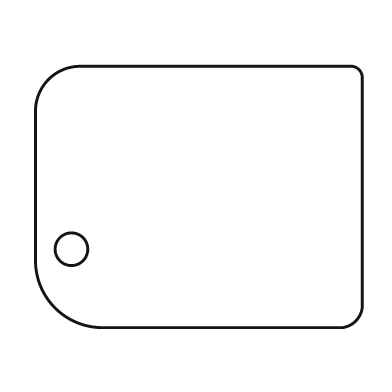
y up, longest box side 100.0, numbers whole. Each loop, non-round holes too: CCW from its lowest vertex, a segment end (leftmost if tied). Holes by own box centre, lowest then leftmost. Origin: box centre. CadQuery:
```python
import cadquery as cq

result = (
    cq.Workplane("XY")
    .moveTo(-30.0, -40.0)
    .lineTo(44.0, -40.0)
    .threePointArc((48.0, -38.0), (50.0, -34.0))
    .lineTo(50.0, 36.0)
    .threePointArc((49.0, 39.0), (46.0, 40.0))
    .lineTo(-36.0, 40.0)
    .threePointArc((-46.0, 36.0), (-50.0, 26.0))
    .lineTo(-50.0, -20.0)
    .threePointArc((-44.0, -34.0), (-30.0, -40.0))
    .close()
    .moveTo(-39.0, -16.0)
    .circle(5.0)
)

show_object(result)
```